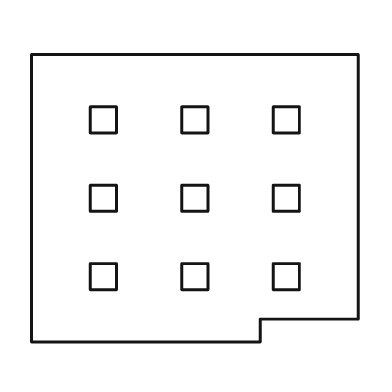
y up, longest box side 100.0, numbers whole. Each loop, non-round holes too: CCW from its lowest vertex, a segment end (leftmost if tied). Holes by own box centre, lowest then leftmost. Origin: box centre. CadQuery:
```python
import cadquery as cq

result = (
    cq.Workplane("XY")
    .moveTo(-50.0, -44.0)
    .lineTo(20.0, -44.0)
    .lineTo(20.0, -37.0)
    .lineTo(50.0, -37.0)
    .lineTo(50.0, 44.0)
    .lineTo(-50.0, 44.0)
    .close()
    .moveTo(-32.0, -28.0)
    .lineTo(-24.0, -28.0)
    .lineTo(-24.0, -20.0)
    .lineTo(-32.0, -20.0)
    .close()
    .moveTo(-4.0, -28.0)
    .lineTo(4.0, -28.0)
    .lineTo(4.0, -20.0)
    .lineTo(-4.0, -20.0)
    .close()
    .moveTo(24.0, -28.0)
    .lineTo(32.0, -28.0)
    .lineTo(32.0, -20.0)
    .lineTo(24.0, -20.0)
    .close()
    .moveTo(-32.0, -4.0)
    .lineTo(-24.0, -4.0)
    .lineTo(-24.0, 4.0)
    .lineTo(-32.0, 4.0)
    .close()
    .moveTo(-4.0, -4.0)
    .lineTo(4.0, -4.0)
    .lineTo(4.0, 4.0)
    .lineTo(-4.0, 4.0)
    .close()
    .moveTo(24.0, -4.0)
    .lineTo(32.0, -4.0)
    .lineTo(32.0, 4.0)
    .lineTo(24.0, 4.0)
    .close()
    .moveTo(-32.0, 20.0)
    .lineTo(-24.0, 20.0)
    .lineTo(-24.0, 28.0)
    .lineTo(-32.0, 28.0)
    .close()
    .moveTo(-4.0, 20.0)
    .lineTo(4.0, 20.0)
    .lineTo(4.0, 28.0)
    .lineTo(-4.0, 28.0)
    .close()
    .moveTo(24.0, 20.0)
    .lineTo(32.0, 20.0)
    .lineTo(32.0, 28.0)
    .lineTo(24.0, 28.0)
    .close()
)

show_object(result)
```